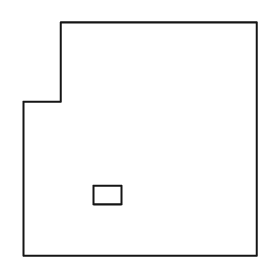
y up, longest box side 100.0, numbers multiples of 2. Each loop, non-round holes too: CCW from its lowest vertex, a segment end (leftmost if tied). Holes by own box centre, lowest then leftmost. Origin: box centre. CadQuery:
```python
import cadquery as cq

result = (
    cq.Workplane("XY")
    .moveTo(-50.0, -50.0)
    .lineTo(50.0, -50.0)
    .lineTo(50.0, 50.0)
    .lineTo(-34.0, 50.0)
    .lineTo(-34.0, 16.0)
    .lineTo(-50.0, 16.0)
    .close()
    .moveTo(-20.0, -28.0)
    .lineTo(-8.0, -28.0)
    .lineTo(-8.0, -20.0)
    .lineTo(-20.0, -20.0)
    .close()
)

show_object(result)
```